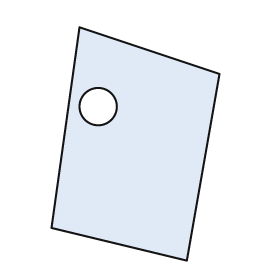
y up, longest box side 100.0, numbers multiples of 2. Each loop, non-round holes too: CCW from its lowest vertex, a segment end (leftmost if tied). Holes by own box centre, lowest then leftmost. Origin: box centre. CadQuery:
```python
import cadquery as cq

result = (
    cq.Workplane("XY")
    .moveTo(22.0, -50.0)
    .lineTo(36.0, 30.0)
    .lineTo(-24.0, 50.0)
    .lineTo(-36.0, -36.0)
    .close()
    .moveTo(-16.0, 16.0)
    .circle(8.0)
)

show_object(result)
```